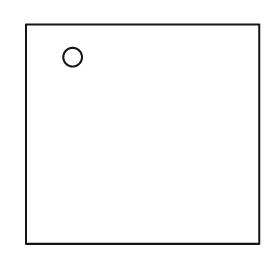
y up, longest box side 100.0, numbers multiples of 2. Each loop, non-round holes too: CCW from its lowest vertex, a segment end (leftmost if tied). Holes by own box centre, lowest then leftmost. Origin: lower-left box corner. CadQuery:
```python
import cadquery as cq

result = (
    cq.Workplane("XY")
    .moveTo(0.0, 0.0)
    .lineTo(100.0, 0.0)
    .lineTo(100.0, 94.0)
    .lineTo(0.0, 94.0)
    .close()
    .moveTo(20.0, 80.0)
    .circle(4.0)
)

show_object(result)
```